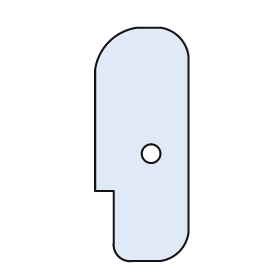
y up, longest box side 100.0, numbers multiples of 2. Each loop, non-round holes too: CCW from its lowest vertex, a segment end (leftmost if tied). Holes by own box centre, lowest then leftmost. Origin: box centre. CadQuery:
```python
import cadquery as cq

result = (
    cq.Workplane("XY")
    .moveTo(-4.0, -50.0)
    .lineTo(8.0, -50.0)
    .threePointArc((16.0, -46.0), (20.0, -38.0))
    .lineTo(20.0, 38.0)
    .threePointArc((16.0, 46.0), (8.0, 50.0))
    .lineTo(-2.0, 50.0)
    .threePointArc((-14.0, 44.0), (-20.0, 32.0))
    .lineTo(-20.0, -20.0)
    .lineTo(-12.0, -20.0)
    .lineTo(-12.0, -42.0)
    .threePointArc((-10.0, -48.0), (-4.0, -50.0))
    .close()
    .moveTo(4.0, -4.0)
    .circle(4.0)
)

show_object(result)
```